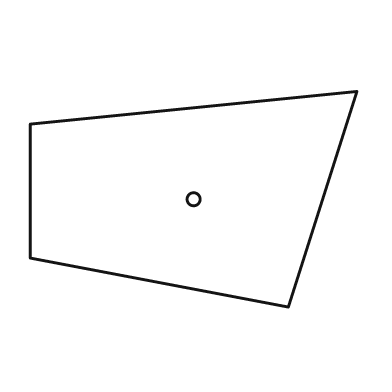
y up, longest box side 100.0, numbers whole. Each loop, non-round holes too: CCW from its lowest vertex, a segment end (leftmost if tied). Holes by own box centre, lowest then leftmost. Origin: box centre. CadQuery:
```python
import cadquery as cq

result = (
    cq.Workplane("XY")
    .moveTo(29.0, -33.0)
    .lineTo(50.0, 33.0)
    .lineTo(-50.0, 23.0)
    .lineTo(-50.0, -18.0)
    .close()
    .moveTo(0.0, 0.0)
    .circle(2.0)
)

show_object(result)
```